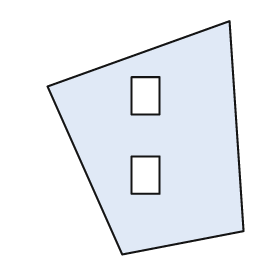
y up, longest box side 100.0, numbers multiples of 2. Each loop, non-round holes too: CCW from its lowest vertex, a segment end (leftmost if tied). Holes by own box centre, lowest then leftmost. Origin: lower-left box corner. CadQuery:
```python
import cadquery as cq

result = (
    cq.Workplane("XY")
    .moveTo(32.0, 0.0)
    .lineTo(84.0, 10.0)
    .lineTo(78.0, 100.0)
    .lineTo(0.0, 72.0)
    .close()
    .moveTo(36.0, 26.0)
    .lineTo(48.0, 26.0)
    .lineTo(48.0, 42.0)
    .lineTo(36.0, 42.0)
    .close()
    .moveTo(36.0, 60.0)
    .lineTo(48.0, 60.0)
    .lineTo(48.0, 76.0)
    .lineTo(36.0, 76.0)
    .close()
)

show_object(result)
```